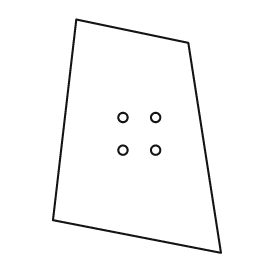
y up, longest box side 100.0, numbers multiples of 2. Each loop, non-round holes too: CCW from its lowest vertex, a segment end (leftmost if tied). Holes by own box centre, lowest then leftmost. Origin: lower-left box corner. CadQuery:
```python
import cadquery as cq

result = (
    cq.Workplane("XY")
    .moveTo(72.0, 0.0)
    .lineTo(58.0, 90.0)
    .lineTo(10.0, 100.0)
    .lineTo(0.0, 14.0)
    .close()
    .moveTo(30.0, 44.0)
    .circle(2.0)
    .moveTo(44.0, 44.0)
    .circle(2.0)
    .moveTo(30.0, 58.0)
    .circle(2.0)
    .moveTo(44.0, 58.0)
    .circle(2.0)
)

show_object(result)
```